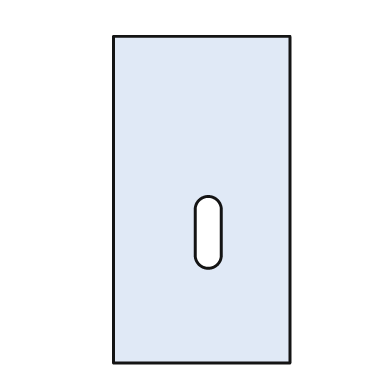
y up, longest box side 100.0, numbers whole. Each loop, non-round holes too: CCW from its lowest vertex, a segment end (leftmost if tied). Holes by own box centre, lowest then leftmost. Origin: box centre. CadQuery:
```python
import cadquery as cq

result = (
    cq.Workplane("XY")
    .moveTo(-27.0, -50.0)
    .lineTo(27.0, -50.0)
    .lineTo(27.0, 50.0)
    .lineTo(-27.0, 50.0)
    .close()
    .moveTo(-2.0, -17.0)
    .threePointArc((2.0, -21.0), (6.0, -17.0))
    .lineTo(6.0, -3.0)
    .threePointArc((2.0, 1.0), (-2.0, -3.0))
    .close()
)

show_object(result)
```